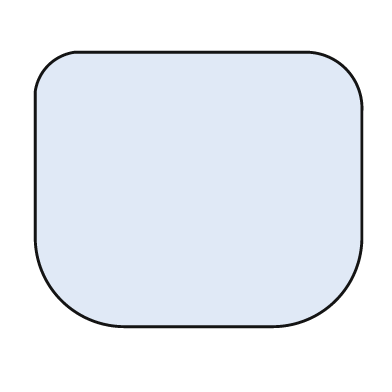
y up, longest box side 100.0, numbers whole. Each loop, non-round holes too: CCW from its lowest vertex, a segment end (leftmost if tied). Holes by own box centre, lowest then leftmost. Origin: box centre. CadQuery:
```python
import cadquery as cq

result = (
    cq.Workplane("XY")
    .moveTo(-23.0, -42.0)
    .lineTo(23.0, -42.0)
    .threePointArc((42.0, -34.0), (50.0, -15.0))
    .lineTo(50.0, 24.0)
    .threePointArc((45.0, 37.0), (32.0, 42.0))
    .lineTo(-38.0, 42.0)
    .threePointArc((-46.0, 38.0), (-50.0, 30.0))
    .lineTo(-50.0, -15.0)
    .threePointArc((-42.0, -34.0), (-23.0, -42.0))
    .close()
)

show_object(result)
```